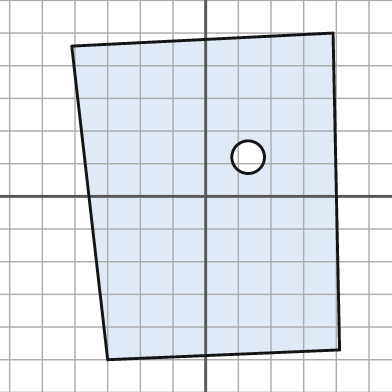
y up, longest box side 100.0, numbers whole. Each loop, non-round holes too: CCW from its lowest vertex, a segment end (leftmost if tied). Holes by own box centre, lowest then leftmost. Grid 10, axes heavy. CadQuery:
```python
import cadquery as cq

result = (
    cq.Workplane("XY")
    .moveTo(-30.0, -50.0)
    .lineTo(41.0, -47.0)
    .lineTo(39.0, 50.0)
    .lineTo(-41.0, 46.0)
    .close()
    .moveTo(13.0, 12.0)
    .circle(5.0)
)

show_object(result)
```